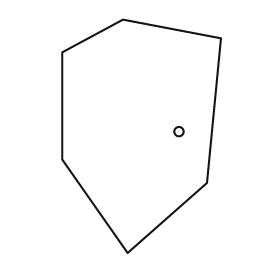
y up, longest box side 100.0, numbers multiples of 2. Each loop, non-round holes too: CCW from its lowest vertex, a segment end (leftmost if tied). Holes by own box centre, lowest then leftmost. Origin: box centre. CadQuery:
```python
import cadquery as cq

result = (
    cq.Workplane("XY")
    .moveTo(-6.0, -50.0)
    .lineTo(28.0, -20.0)
    .lineTo(34.0, 42.0)
    .lineTo(-8.0, 50.0)
    .lineTo(-34.0, 36.0)
    .lineTo(-34.0, -10.0)
    .close()
    .moveTo(16.0, 2.0)
    .circle(2.0)
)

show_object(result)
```